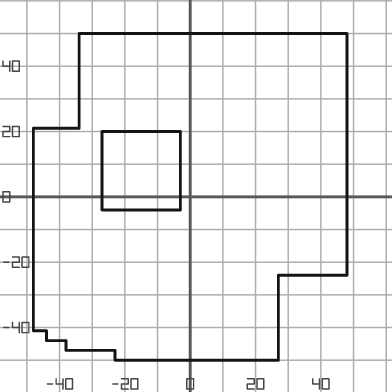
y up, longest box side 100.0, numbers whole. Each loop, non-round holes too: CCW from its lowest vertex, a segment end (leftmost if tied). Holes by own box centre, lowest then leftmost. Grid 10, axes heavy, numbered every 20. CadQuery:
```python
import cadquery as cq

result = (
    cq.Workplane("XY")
    .moveTo(-23.0, -50.0)
    .lineTo(27.0, -50.0)
    .lineTo(27.0, -24.0)
    .lineTo(48.0, -24.0)
    .lineTo(48.0, 50.0)
    .lineTo(-34.0, 50.0)
    .lineTo(-34.0, 21.0)
    .lineTo(-48.0, 21.0)
    .lineTo(-48.0, -41.0)
    .lineTo(-44.0, -41.0)
    .lineTo(-44.0, -44.0)
    .lineTo(-38.0, -44.0)
    .lineTo(-38.0, -47.0)
    .lineTo(-23.0, -47.0)
    .close()
    .moveTo(-27.0, -4.0)
    .lineTo(-3.0, -4.0)
    .lineTo(-3.0, 20.0)
    .lineTo(-27.0, 20.0)
    .close()
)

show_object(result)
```